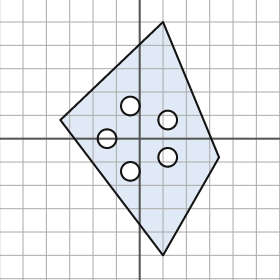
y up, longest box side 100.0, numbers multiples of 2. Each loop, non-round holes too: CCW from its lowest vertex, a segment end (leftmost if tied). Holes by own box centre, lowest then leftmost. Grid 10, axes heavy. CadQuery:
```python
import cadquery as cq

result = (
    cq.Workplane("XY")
    .moveTo(10.0, -50.0)
    .lineTo(34.0, -8.0)
    .lineTo(10.0, 50.0)
    .lineTo(-34.0, 8.0)
    .close()
    .moveTo(-4.0, -14.0)
    .circle(4.0)
    .moveTo(12.0, -8.0)
    .circle(4.0)
    .moveTo(-14.0, 0.0)
    .circle(4.0)
    .moveTo(12.0, 8.0)
    .circle(4.0)
    .moveTo(-4.0, 14.0)
    .circle(4.0)
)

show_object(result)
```